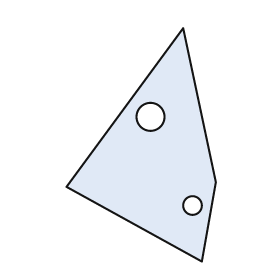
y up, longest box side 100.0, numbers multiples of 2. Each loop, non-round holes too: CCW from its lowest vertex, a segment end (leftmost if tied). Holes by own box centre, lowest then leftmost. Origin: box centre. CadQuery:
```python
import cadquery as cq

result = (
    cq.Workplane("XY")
    .moveTo(26.0, -50.0)
    .lineTo(32.0, -16.0)
    .lineTo(18.0, 50.0)
    .lineTo(-32.0, -18.0)
    .close()
    .moveTo(22.0, -26.0)
    .circle(4.0)
    .moveTo(4.0, 12.0)
    .circle(6.0)
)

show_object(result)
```